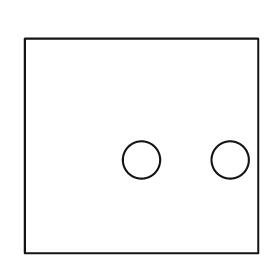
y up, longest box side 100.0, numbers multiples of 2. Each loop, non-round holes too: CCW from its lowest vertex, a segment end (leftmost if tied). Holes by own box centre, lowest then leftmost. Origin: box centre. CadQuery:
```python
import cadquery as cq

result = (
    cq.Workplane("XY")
    .moveTo(-50.0, -46.0)
    .lineTo(50.0, -46.0)
    .lineTo(50.0, 46.0)
    .lineTo(-50.0, 46.0)
    .close()
    .moveTo(0.0, -6.0)
    .circle(8.0)
    .moveTo(38.0, -6.0)
    .circle(8.0)
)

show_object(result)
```